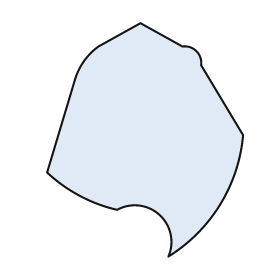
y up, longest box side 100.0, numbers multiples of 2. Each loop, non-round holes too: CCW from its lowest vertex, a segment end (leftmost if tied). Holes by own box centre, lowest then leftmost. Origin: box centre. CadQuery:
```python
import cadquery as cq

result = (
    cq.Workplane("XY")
    .moveTo(10.0, -50.0)
    .threePointArc((32.0, -28.0), (42.0, 2.0))
    .lineTo(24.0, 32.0)
    .threePointArc((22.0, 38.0), (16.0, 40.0))
    .lineTo(-2.0, 50.0)
    .lineTo(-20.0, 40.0)
    .threePointArc((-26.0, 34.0), (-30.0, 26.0))
    .lineTo(-42.0, -14.0)
    .threePointArc((-28.0, -24.0), (-12.0, -30.0))
    .threePointArc((6.0, -32.0), (10.0, -50.0))
    .close()
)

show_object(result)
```